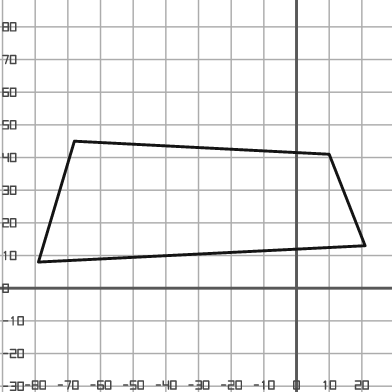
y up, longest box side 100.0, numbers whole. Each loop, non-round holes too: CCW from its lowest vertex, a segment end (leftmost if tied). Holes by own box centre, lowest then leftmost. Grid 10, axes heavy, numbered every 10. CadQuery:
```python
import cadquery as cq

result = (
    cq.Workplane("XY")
    .moveTo(-79.0, 8.0)
    .lineTo(21.0, 13.0)
    .lineTo(10.0, 41.0)
    .lineTo(-68.0, 45.0)
    .close()
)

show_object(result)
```